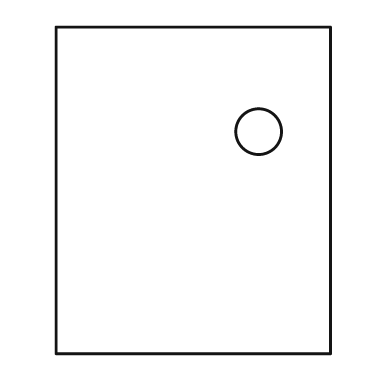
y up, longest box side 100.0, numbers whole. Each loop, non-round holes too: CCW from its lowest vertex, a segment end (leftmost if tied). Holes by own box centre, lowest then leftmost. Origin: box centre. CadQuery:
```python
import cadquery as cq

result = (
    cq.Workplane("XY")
    .moveTo(-42.0, -50.0)
    .lineTo(42.0, -50.0)
    .lineTo(42.0, 50.0)
    .lineTo(-42.0, 50.0)
    .close()
    .moveTo(20.0, 18.0)
    .circle(7.0)
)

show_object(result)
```